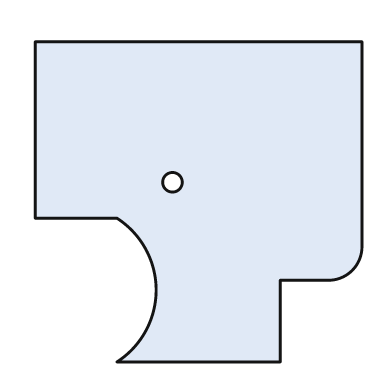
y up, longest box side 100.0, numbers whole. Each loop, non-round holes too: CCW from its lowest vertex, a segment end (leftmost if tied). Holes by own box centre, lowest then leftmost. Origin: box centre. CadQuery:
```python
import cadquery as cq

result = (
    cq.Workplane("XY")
    .moveTo(-25.0, -49.0)
    .lineTo(25.0, -49.0)
    .lineTo(25.0, -24.0)
    .lineTo(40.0, -24.0)
    .threePointArc((47.0, -21.0), (50.0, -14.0))
    .lineTo(50.0, 49.0)
    .lineTo(-50.0, 49.0)
    .lineTo(-50.0, -5.0)
    .lineTo(-25.0, -5.0)
    .threePointArc((-13.0, -27.0), (-25.0, -49.0))
    .close()
    .moveTo(-8.0, 6.0)
    .circle(3.0)
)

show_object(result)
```